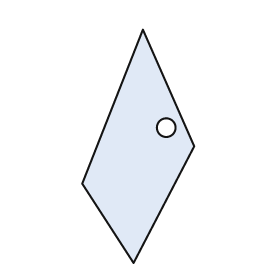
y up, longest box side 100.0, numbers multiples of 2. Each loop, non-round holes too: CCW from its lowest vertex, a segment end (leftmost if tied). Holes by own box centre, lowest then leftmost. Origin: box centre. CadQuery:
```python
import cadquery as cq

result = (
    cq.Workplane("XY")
    .moveTo(-2.0, -50.0)
    .lineTo(24.0, 0.0)
    .lineTo(2.0, 50.0)
    .lineTo(-24.0, -16.0)
    .close()
    .moveTo(12.0, 8.0)
    .circle(4.0)
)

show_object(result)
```